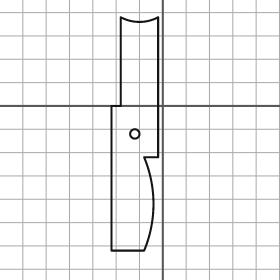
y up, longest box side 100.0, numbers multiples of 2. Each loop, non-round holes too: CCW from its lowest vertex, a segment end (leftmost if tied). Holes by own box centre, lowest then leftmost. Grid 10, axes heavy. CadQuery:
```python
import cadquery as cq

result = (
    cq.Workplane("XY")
    .moveTo(-22.0, -62.0)
    .lineTo(-8.0, -62.0)
    .threePointArc((-4.0, -42.0), (-8.0, -22.0))
    .lineTo(-2.0, -22.0)
    .lineTo(-2.0, 38.0)
    .threePointArc((-10.0, 36.0), (-18.0, 38.0))
    .lineTo(-18.0, 0.0)
    .lineTo(-22.0, 0.0)
    .close()
    .moveTo(-12.0, -12.0)
    .circle(2.0)
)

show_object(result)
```